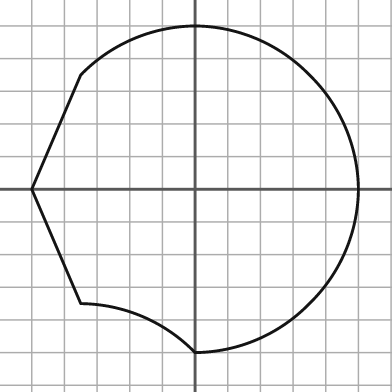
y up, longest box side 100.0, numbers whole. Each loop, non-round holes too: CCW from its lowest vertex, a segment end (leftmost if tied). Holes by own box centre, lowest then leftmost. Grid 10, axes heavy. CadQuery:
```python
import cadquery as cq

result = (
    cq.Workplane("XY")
    .moveTo(0.0, -50.0)
    .threePointArc((19.0, -46.0), (35.0, -35.0))
    .threePointArc((46.0, -19.0), (50.0, 0.0))
    .threePointArc((46.0, 19.0), (35.0, 35.0))
    .threePointArc((19.0, 46.0), (0.0, 50.0))
    .threePointArc((-19.0, 46.0), (-35.0, 35.0))
    .lineTo(-50.0, 0.0)
    .lineTo(-35.0, -35.0)
    .threePointArc((-16.0, -39.0), (0.0, -50.0))
    .close()
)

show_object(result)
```